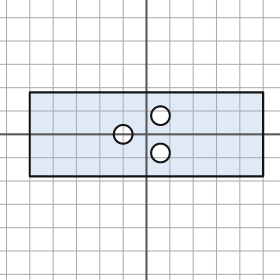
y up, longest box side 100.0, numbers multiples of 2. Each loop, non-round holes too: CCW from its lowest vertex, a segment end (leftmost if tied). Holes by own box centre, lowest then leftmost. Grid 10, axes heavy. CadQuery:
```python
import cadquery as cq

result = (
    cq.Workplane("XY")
    .moveTo(-50.0, -18.0)
    .lineTo(50.0, -18.0)
    .lineTo(50.0, 18.0)
    .lineTo(-50.0, 18.0)
    .close()
    .moveTo(6.0, -8.0)
    .circle(4.0)
    .moveTo(-10.0, 0.0)
    .circle(4.0)
    .moveTo(6.0, 8.0)
    .circle(4.0)
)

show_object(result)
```